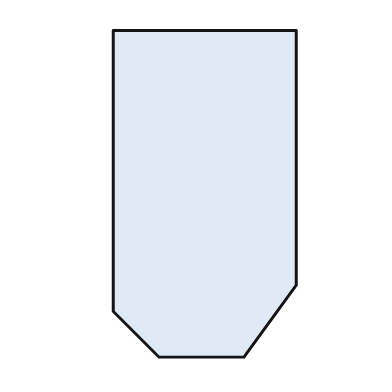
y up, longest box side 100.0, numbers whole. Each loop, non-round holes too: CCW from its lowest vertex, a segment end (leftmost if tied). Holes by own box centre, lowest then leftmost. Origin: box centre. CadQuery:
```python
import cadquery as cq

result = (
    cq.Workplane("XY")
    .moveTo(-14.0, -50.0)
    .lineTo(12.0, -50.0)
    .lineTo(28.0, -28.0)
    .lineTo(28.0, 50.0)
    .lineTo(-28.0, 50.0)
    .lineTo(-28.0, -36.0)
    .close()
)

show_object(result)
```